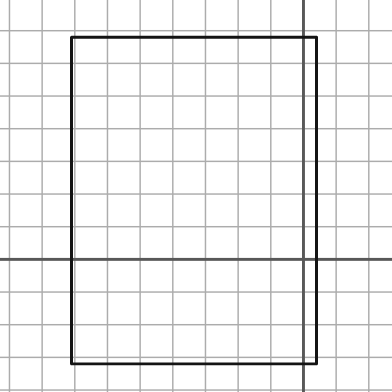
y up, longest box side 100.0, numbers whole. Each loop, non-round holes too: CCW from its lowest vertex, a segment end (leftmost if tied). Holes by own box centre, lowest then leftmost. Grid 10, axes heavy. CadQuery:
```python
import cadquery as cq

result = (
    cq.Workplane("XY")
    .moveTo(-71.0, -32.0)
    .lineTo(4.0, -32.0)
    .lineTo(4.0, 68.0)
    .lineTo(-71.0, 68.0)
    .close()
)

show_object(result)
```